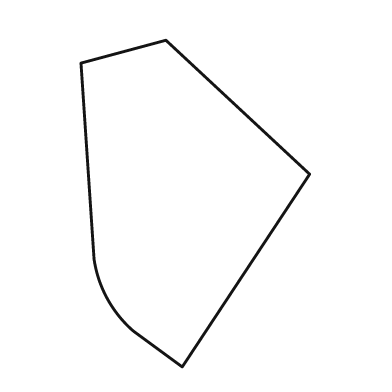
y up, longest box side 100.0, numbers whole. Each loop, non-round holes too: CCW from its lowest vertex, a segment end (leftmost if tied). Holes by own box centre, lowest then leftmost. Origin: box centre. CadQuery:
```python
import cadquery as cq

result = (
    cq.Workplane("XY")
    .moveTo(-4.0, -50.0)
    .lineTo(35.0, 9.0)
    .lineTo(-9.0, 50.0)
    .lineTo(-35.0, 43.0)
    .lineTo(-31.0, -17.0)
    .threePointArc((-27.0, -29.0), (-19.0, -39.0))
    .close()
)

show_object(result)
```